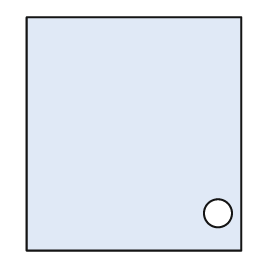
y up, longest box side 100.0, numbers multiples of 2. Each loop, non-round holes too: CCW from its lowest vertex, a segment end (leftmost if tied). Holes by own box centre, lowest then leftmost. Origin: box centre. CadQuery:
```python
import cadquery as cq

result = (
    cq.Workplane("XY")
    .moveTo(-46.0, -50.0)
    .lineTo(46.0, -50.0)
    .lineTo(46.0, 50.0)
    .lineTo(-46.0, 50.0)
    .close()
    .moveTo(36.0, -34.0)
    .circle(6.0)
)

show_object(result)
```